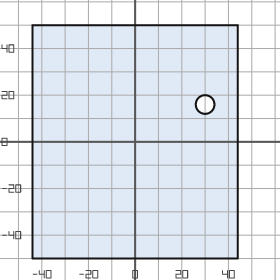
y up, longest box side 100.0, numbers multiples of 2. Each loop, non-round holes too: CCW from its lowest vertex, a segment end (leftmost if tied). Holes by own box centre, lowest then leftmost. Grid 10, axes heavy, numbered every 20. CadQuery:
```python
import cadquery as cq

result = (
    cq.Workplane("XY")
    .moveTo(-44.0, -50.0)
    .lineTo(44.0, -50.0)
    .lineTo(44.0, 50.0)
    .lineTo(-44.0, 50.0)
    .close()
    .moveTo(30.0, 16.0)
    .circle(4.0)
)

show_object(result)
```